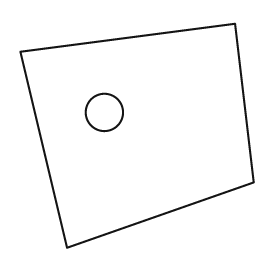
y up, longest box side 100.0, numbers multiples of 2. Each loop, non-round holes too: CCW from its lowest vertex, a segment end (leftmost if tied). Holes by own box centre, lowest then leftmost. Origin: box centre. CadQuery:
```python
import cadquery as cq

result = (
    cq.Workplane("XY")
    .moveTo(-30.0, -48.0)
    .lineTo(50.0, -20.0)
    .lineTo(42.0, 48.0)
    .lineTo(-50.0, 36.0)
    .close()
    .moveTo(-14.0, 10.0)
    .circle(8.0)
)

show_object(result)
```